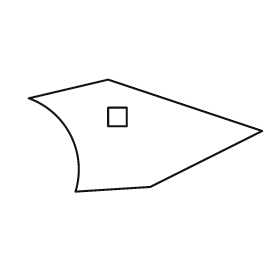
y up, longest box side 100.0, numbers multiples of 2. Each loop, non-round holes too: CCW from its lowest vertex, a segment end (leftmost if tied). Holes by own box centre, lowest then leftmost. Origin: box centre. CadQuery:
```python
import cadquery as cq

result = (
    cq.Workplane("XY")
    .moveTo(-30.0, -24.0)
    .lineTo(2.0, -22.0)
    .lineTo(50.0, 2.0)
    .lineTo(-16.0, 24.0)
    .lineTo(-50.0, 16.0)
    .threePointArc((-32.0, 0.0), (-30.0, -24.0))
    .close()
    .moveTo(-16.0, 4.0)
    .lineTo(-8.0, 4.0)
    .lineTo(-8.0, 12.0)
    .lineTo(-16.0, 12.0)
    .close()
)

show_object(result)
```